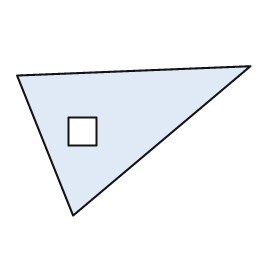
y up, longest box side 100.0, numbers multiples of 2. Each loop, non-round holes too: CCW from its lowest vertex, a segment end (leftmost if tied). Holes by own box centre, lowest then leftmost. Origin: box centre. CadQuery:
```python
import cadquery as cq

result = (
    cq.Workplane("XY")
    .moveTo(-26.0, -32.0)
    .lineTo(50.0, 32.0)
    .lineTo(-50.0, 28.0)
    .close()
    .moveTo(-28.0, -2.0)
    .lineTo(-16.0, -2.0)
    .lineTo(-16.0, 10.0)
    .lineTo(-28.0, 10.0)
    .close()
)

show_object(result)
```